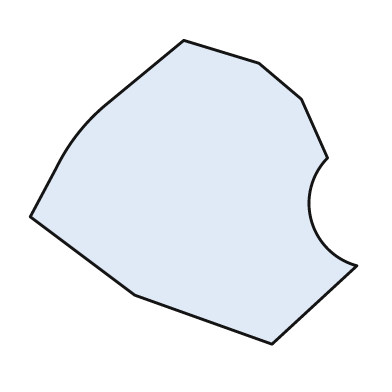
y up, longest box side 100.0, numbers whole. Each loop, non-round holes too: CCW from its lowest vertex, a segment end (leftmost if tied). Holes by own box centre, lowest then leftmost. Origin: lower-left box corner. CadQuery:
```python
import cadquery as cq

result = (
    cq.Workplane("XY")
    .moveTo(74.0, 0.0)
    .lineTo(100.0, 24.0)
    .threePointArc((86.0, 38.0), (91.0, 57.0))
    .lineTo(83.0, 75.0)
    .lineTo(70.0, 86.0)
    .lineTo(47.0, 93.0)
    .lineTo(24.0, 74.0)
    .threePointArc((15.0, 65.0), (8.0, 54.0))
    .lineTo(0.0, 39.0)
    .lineTo(32.0, 15.0)
    .close()
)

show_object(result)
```